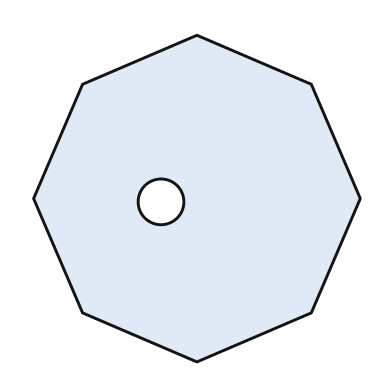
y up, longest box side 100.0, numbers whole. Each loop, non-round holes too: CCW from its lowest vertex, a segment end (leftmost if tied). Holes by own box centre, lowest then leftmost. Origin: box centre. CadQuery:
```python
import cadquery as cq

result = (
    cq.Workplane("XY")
    .moveTo(0.0, -50.0)
    .lineTo(35.0, -35.0)
    .lineTo(50.0, 0.0)
    .lineTo(35.0, 35.0)
    .lineTo(0.0, 50.0)
    .lineTo(-35.0, 35.0)
    .lineTo(-50.0, 0.0)
    .lineTo(-35.0, -35.0)
    .close()
    .moveTo(-11.0, -1.0)
    .circle(7.0)
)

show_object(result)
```